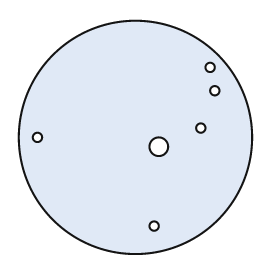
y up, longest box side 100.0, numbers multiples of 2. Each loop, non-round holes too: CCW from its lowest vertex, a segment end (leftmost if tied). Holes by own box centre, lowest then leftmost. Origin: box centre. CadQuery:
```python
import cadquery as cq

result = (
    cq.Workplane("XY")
    .moveTo(0.0, 0.0)
    .circle(50.0)
    .moveTo(8.0, -38.0)
    .circle(2.0)
    .moveTo(10.0, -4.0)
    .circle(4.0)
    .moveTo(-42.0, 0.0)
    .circle(2.0)
    .moveTo(28.0, 4.0)
    .circle(2.0)
    .moveTo(34.0, 20.0)
    .circle(2.0)
    .moveTo(32.0, 30.0)
    .circle(2.0)
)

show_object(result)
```